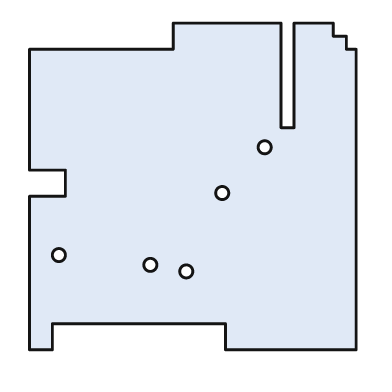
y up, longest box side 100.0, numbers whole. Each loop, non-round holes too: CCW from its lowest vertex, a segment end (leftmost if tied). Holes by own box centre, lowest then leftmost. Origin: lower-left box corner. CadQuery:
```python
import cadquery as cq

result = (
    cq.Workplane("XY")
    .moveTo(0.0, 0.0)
    .lineTo(7.0, 0.0)
    .lineTo(7.0, 8.0)
    .lineTo(60.0, 8.0)
    .lineTo(60.0, 0.0)
    .lineTo(100.0, 0.0)
    .lineTo(100.0, 92.0)
    .lineTo(97.0, 92.0)
    .lineTo(97.0, 96.0)
    .lineTo(93.0, 96.0)
    .lineTo(93.0, 100.0)
    .lineTo(81.0, 100.0)
    .lineTo(81.0, 68.0)
    .lineTo(77.0, 68.0)
    .lineTo(77.0, 100.0)
    .lineTo(44.0, 100.0)
    .lineTo(44.0, 92.0)
    .lineTo(0.0, 92.0)
    .lineTo(0.0, 55.0)
    .lineTo(11.0, 55.0)
    .lineTo(11.0, 47.0)
    .lineTo(0.0, 47.0)
    .close()
    .moveTo(48.0, 24.0)
    .circle(2.0)
    .moveTo(37.0, 26.0)
    .circle(2.0)
    .moveTo(9.0, 29.0)
    .circle(2.0)
    .moveTo(59.0, 48.0)
    .circle(2.0)
    .moveTo(72.0, 62.0)
    .circle(2.0)
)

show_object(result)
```